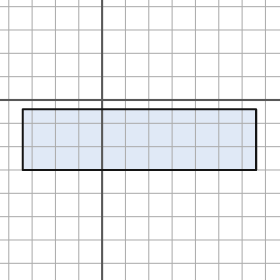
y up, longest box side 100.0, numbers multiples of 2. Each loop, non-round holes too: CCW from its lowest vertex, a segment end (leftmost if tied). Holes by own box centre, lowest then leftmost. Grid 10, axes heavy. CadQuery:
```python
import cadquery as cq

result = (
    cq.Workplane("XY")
    .moveTo(-34.0, -30.0)
    .lineTo(66.0, -30.0)
    .lineTo(66.0, -4.0)
    .lineTo(-34.0, -4.0)
    .close()
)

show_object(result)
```